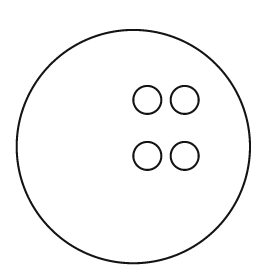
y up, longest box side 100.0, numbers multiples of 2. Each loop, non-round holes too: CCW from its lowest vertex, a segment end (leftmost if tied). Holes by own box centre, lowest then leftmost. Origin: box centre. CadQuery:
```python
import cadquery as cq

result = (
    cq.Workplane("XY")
    .moveTo(0.0, 0.0)
    .circle(50.0)
    .moveTo(6.0, -4.0)
    .circle(6.0)
    .moveTo(22.0, -4.0)
    .circle(6.0)
    .moveTo(6.0, 20.0)
    .circle(6.0)
    .moveTo(22.0, 20.0)
    .circle(6.0)
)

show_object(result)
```